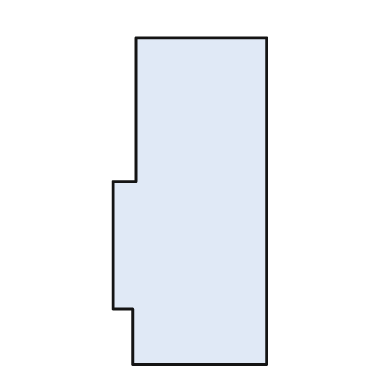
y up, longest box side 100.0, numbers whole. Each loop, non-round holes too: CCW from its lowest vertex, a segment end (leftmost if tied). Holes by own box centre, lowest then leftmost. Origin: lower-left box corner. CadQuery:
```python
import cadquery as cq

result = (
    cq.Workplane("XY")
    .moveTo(6.0, 0.0)
    .lineTo(47.0, 0.0)
    .lineTo(47.0, 100.0)
    .lineTo(7.0, 100.0)
    .lineTo(7.0, 56.0)
    .lineTo(0.0, 56.0)
    .lineTo(0.0, 17.0)
    .lineTo(6.0, 17.0)
    .close()
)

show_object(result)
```